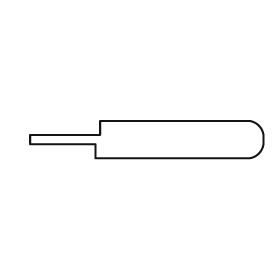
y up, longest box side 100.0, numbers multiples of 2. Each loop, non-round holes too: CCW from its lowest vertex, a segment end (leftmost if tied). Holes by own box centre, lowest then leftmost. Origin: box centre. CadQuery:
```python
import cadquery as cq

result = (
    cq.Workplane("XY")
    .moveTo(-22.0, -8.0)
    .lineTo(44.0, -8.0)
    .threePointArc((48.0, -6.0), (50.0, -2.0))
    .lineTo(50.0, 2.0)
    .threePointArc((48.0, 6.0), (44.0, 8.0))
    .lineTo(-20.0, 8.0)
    .lineTo(-20.0, 2.0)
    .lineTo(-50.0, 2.0)
    .lineTo(-50.0, -2.0)
    .lineTo(-22.0, -2.0)
    .close()
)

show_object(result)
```